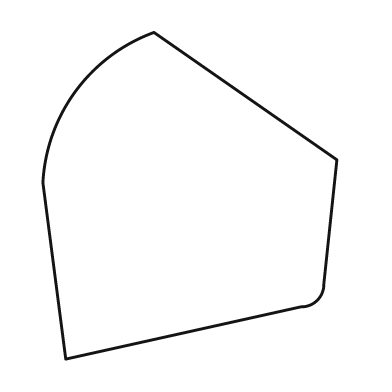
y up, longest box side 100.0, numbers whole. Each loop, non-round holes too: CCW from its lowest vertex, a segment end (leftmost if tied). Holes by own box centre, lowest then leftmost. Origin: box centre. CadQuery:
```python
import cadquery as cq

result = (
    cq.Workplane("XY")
    .moveTo(-38.0, -50.0)
    .lineTo(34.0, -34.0)
    .threePointArc((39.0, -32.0), (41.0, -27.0))
    .lineTo(45.0, 11.0)
    .lineTo(-11.0, 50.0)
    .threePointArc((-35.0, 32.0), (-45.0, 4.0))
    .close()
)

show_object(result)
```